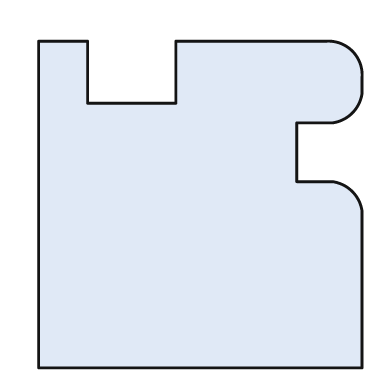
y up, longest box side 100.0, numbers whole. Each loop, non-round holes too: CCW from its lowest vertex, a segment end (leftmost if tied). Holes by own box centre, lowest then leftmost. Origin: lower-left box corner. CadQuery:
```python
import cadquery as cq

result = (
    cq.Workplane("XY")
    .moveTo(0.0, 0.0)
    .lineTo(99.0, 0.0)
    .lineTo(99.0, 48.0)
    .threePointArc((96.0, 54.0), (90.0, 57.0))
    .lineTo(79.0, 57.0)
    .lineTo(79.0, 75.0)
    .lineTo(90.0, 75.0)
    .threePointArc((96.0, 78.0), (99.0, 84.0))
    .lineTo(99.0, 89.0)
    .threePointArc((96.0, 97.0), (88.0, 100.0))
    .lineTo(42.0, 100.0)
    .lineTo(42.0, 81.0)
    .lineTo(15.0, 81.0)
    .lineTo(15.0, 100.0)
    .lineTo(0.0, 100.0)
    .close()
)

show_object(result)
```